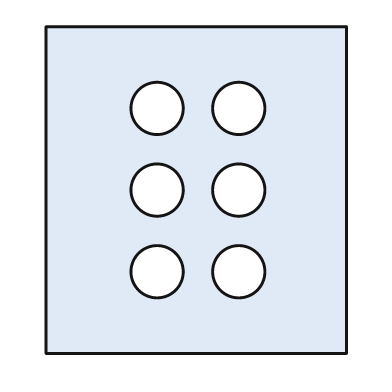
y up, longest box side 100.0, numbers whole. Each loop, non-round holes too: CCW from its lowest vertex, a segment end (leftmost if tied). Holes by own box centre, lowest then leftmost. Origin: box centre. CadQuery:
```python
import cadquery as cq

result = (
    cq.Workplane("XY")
    .moveTo(-46.0, -50.0)
    .lineTo(46.0, -50.0)
    .lineTo(46.0, 50.0)
    .lineTo(-46.0, 50.0)
    .close()
    .moveTo(-12.0, -25.0)
    .circle(8.0)
    .moveTo(13.0, -25.0)
    .circle(8.0)
    .moveTo(-12.0, 0.0)
    .circle(8.0)
    .moveTo(13.0, 0.0)
    .circle(8.0)
    .moveTo(-12.0, 25.0)
    .circle(8.0)
    .moveTo(13.0, 25.0)
    .circle(8.0)
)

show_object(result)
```